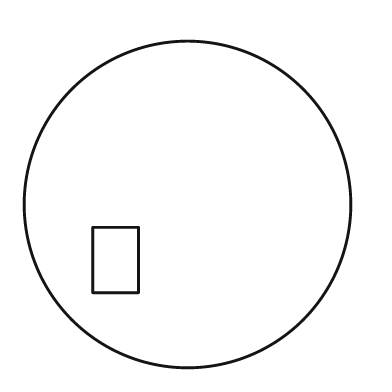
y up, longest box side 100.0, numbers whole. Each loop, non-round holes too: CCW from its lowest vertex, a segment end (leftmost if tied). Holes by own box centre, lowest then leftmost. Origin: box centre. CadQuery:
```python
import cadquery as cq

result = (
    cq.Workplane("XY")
    .moveTo(0.0, 0.0)
    .circle(50.0)
    .moveTo(-29.0, -27.0)
    .lineTo(-15.0, -27.0)
    .lineTo(-15.0, -7.0)
    .lineTo(-29.0, -7.0)
    .close()
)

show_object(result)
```